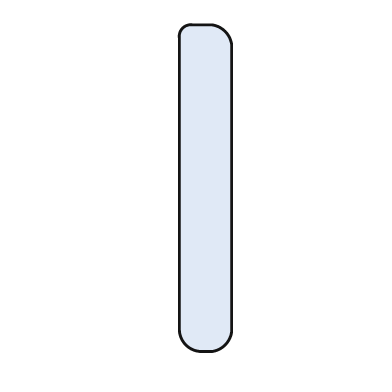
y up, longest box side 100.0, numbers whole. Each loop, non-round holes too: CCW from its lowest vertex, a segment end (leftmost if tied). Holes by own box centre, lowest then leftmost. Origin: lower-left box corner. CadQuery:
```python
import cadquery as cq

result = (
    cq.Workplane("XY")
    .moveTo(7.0, 0.0)
    .lineTo(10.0, 0.0)
    .threePointArc((14.0, 2.0), (16.0, 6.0))
    .lineTo(16.0, 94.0)
    .threePointArc((14.0, 98.0), (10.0, 100.0))
    .lineTo(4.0, 100.0)
    .threePointArc((1.0, 99.0), (0.0, 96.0))
    .lineTo(0.0, 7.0)
    .threePointArc((2.0, 2.0), (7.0, 0.0))
    .close()
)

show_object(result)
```